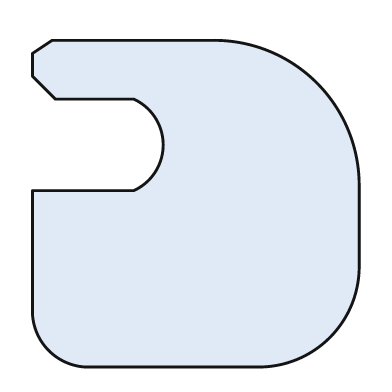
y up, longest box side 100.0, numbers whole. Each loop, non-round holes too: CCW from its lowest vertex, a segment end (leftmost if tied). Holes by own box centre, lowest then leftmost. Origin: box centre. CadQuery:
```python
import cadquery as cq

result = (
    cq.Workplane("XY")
    .moveTo(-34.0, -50.0)
    .lineTo(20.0, -50.0)
    .threePointArc((41.0, -41.0), (50.0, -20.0))
    .lineTo(50.0, 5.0)
    .threePointArc((37.0, 37.0), (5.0, 50.0))
    .lineTo(-44.0, 50.0)
    .lineTo(-50.0, 46.0)
    .lineTo(-50.0, 39.0)
    .lineTo(-43.0, 32.0)
    .lineTo(-19.0, 32.0)
    .threePointArc((-10.0, 18.0), (-19.0, 4.0))
    .lineTo(-50.0, 4.0)
    .lineTo(-50.0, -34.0)
    .threePointArc((-45.0, -45.0), (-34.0, -50.0))
    .close()
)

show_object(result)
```